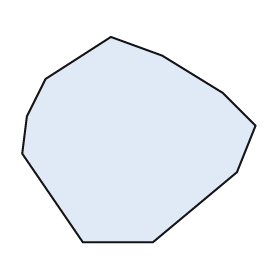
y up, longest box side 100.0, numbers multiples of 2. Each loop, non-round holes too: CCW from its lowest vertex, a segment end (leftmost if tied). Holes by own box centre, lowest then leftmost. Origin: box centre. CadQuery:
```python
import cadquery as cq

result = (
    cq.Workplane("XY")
    .moveTo(-24.0, -44.0)
    .lineTo(6.0, -44.0)
    .lineTo(42.0, -14.0)
    .lineTo(50.0, 6.0)
    .lineTo(36.0, 20.0)
    .lineTo(10.0, 36.0)
    .lineTo(-12.0, 44.0)
    .lineTo(-40.0, 26.0)
    .lineTo(-48.0, 10.0)
    .lineTo(-50.0, -6.0)
    .close()
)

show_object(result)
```